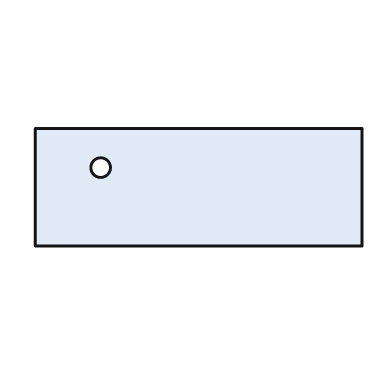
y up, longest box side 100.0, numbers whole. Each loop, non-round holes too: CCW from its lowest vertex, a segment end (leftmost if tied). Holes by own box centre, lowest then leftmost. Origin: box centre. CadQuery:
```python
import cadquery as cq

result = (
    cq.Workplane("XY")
    .moveTo(-50.0, -18.0)
    .lineTo(50.0, -18.0)
    .lineTo(50.0, 18.0)
    .lineTo(-50.0, 18.0)
    .close()
    .moveTo(-30.0, 6.0)
    .circle(3.0)
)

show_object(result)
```